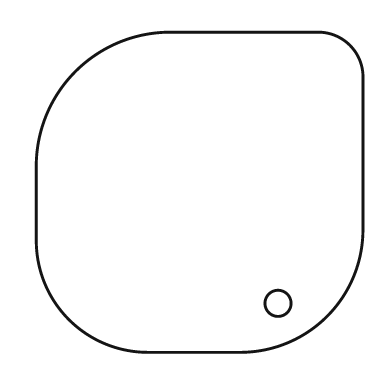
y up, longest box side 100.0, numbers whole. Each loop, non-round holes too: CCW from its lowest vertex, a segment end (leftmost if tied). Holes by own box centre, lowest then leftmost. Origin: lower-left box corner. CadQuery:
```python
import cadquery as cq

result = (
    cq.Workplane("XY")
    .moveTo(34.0, 0.0)
    .lineTo(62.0, 0.0)
    .threePointArc((89.0, 11.0), (100.0, 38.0))
    .lineTo(100.0, 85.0)
    .threePointArc((96.0, 94.0), (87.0, 98.0))
    .lineTo(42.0, 98.0)
    .threePointArc((12.0, 86.0), (0.0, 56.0))
    .lineTo(0.0, 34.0)
    .threePointArc((10.0, 10.0), (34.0, 0.0))
    .close()
    .moveTo(74.0, 15.0)
    .circle(4.0)
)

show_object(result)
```